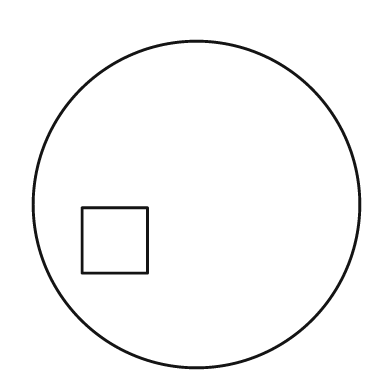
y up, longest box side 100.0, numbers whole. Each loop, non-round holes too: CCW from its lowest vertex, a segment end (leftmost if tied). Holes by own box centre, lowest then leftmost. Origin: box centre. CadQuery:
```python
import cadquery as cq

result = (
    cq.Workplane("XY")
    .moveTo(0.0, 0.0)
    .circle(50.0)
    .moveTo(-35.0, -21.0)
    .lineTo(-15.0, -21.0)
    .lineTo(-15.0, -1.0)
    .lineTo(-35.0, -1.0)
    .close()
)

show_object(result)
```